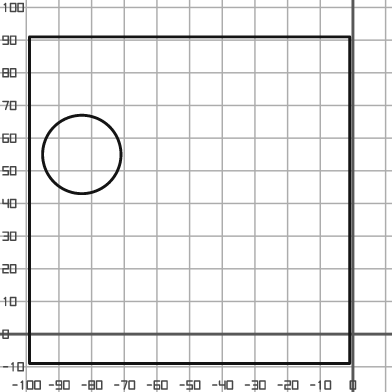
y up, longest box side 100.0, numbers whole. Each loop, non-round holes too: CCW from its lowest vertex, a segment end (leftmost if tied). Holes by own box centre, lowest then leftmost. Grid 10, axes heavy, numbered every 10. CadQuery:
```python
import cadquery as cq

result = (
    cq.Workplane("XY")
    .moveTo(-99.0, -9.0)
    .lineTo(-1.0, -9.0)
    .lineTo(-1.0, 91.0)
    .lineTo(-99.0, 91.0)
    .close()
    .moveTo(-83.0, 55.0)
    .circle(12.0)
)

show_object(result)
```